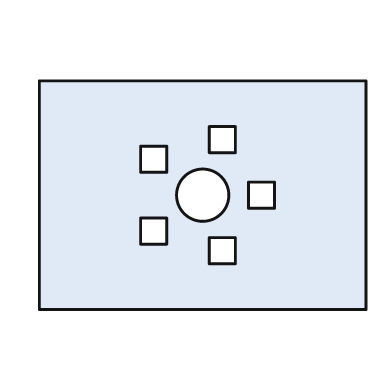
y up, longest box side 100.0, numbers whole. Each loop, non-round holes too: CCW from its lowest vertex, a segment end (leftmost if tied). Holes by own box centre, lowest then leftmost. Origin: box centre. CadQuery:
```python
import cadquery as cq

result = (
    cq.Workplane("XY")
    .moveTo(-50.0, -35.0)
    .lineTo(50.0, -35.0)
    .lineTo(50.0, 35.0)
    .lineTo(-50.0, 35.0)
    .close()
    .moveTo(2.0, -21.0)
    .lineTo(10.0, -21.0)
    .lineTo(10.0, -13.0)
    .lineTo(2.0, -13.0)
    .close()
    .moveTo(-19.0, -15.0)
    .lineTo(-11.0, -15.0)
    .lineTo(-11.0, -7.0)
    .lineTo(-19.0, -7.0)
    .close()
    .moveTo(0.0, 0.0)
    .circle(8.0)
    .moveTo(14.0, -4.0)
    .lineTo(22.0, -4.0)
    .lineTo(22.0, 4.0)
    .lineTo(14.0, 4.0)
    .close()
    .moveTo(-19.0, 7.0)
    .lineTo(-11.0, 7.0)
    .lineTo(-11.0, 15.0)
    .lineTo(-19.0, 15.0)
    .close()
    .moveTo(2.0, 13.0)
    .lineTo(10.0, 13.0)
    .lineTo(10.0, 21.0)
    .lineTo(2.0, 21.0)
    .close()
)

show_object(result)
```